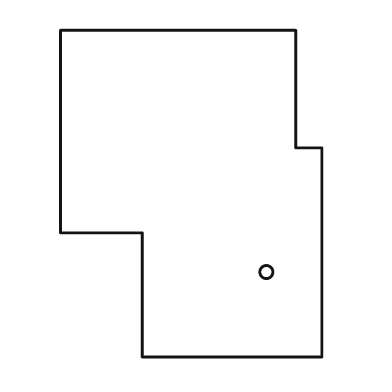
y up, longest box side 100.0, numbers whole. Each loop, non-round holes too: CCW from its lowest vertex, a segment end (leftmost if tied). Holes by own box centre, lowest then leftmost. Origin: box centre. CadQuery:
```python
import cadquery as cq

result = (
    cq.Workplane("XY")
    .moveTo(-15.0, -50.0)
    .lineTo(40.0, -50.0)
    .lineTo(40.0, 14.0)
    .lineTo(32.0, 14.0)
    .lineTo(32.0, 50.0)
    .lineTo(-40.0, 50.0)
    .lineTo(-40.0, -12.0)
    .lineTo(-15.0, -12.0)
    .close()
    .moveTo(23.0, -24.0)
    .circle(2.0)
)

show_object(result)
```